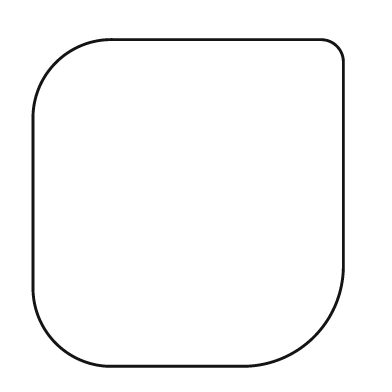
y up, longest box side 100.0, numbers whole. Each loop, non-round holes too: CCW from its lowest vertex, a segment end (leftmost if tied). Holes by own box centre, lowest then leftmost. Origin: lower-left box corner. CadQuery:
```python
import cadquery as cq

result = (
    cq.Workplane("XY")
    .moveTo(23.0, 0.0)
    .lineTo(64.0, 0.0)
    .threePointArc((86.0, 9.0), (95.0, 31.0))
    .lineTo(95.0, 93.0)
    .threePointArc((93.0, 98.0), (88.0, 100.0))
    .lineTo(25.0, 100.0)
    .threePointArc((7.0, 93.0), (0.0, 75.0))
    .lineTo(0.0, 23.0)
    .threePointArc((7.0, 7.0), (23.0, 0.0))
    .close()
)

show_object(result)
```